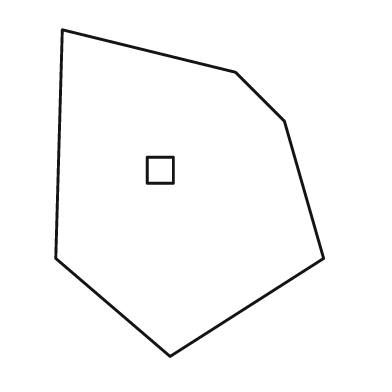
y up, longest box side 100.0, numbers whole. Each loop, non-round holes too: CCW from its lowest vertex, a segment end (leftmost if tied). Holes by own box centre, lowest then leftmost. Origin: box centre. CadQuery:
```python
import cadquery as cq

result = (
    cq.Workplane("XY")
    .moveTo(-6.0, -50.0)
    .lineTo(41.0, -20.0)
    .lineTo(29.0, 22.0)
    .lineTo(14.0, 37.0)
    .lineTo(-39.0, 50.0)
    .lineTo(-41.0, -20.0)
    .close()
    .moveTo(-13.0, 3.0)
    .lineTo(-5.0, 3.0)
    .lineTo(-5.0, 11.0)
    .lineTo(-13.0, 11.0)
    .close()
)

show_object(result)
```